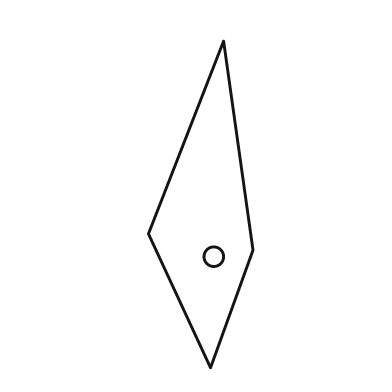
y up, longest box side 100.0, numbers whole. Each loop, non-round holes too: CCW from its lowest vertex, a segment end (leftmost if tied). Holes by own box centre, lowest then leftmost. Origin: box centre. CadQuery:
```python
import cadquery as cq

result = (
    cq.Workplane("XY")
    .moveTo(3.0, -50.0)
    .lineTo(16.0, -14.0)
    .lineTo(7.0, 50.0)
    .lineTo(-16.0, -9.0)
    .close()
    .moveTo(4.0, -16.0)
    .circle(3.0)
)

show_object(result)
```